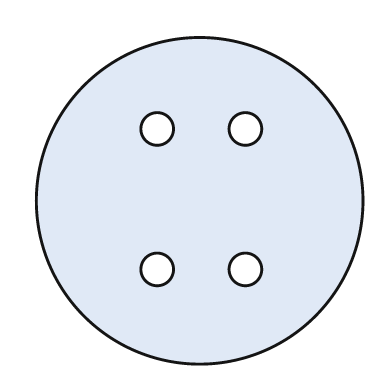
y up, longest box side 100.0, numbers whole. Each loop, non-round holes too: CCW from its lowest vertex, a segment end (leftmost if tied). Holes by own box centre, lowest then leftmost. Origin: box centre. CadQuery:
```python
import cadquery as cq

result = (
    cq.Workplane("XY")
    .moveTo(0.0, 0.0)
    .circle(50.0)
    .moveTo(-13.0, -21.0)
    .circle(5.0)
    .moveTo(14.0, -21.0)
    .circle(5.0)
    .moveTo(-13.0, 22.0)
    .circle(5.0)
    .moveTo(14.0, 22.0)
    .circle(5.0)
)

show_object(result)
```